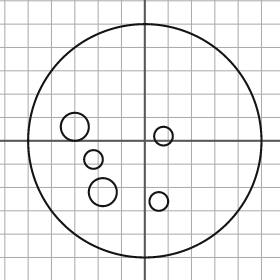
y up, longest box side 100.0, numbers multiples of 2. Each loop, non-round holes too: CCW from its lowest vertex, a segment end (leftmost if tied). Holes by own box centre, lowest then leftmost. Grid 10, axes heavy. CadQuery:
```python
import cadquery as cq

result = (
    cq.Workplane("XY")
    .moveTo(0.0, 0.0)
    .circle(50.0)
    .moveTo(6.0, -26.0)
    .circle(4.0)
    .moveTo(-18.0, -22.0)
    .circle(6.0)
    .moveTo(-22.0, -8.0)
    .circle(4.0)
    .moveTo(8.0, 2.0)
    .circle(4.0)
    .moveTo(-30.0, 6.0)
    .circle(6.0)
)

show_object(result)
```